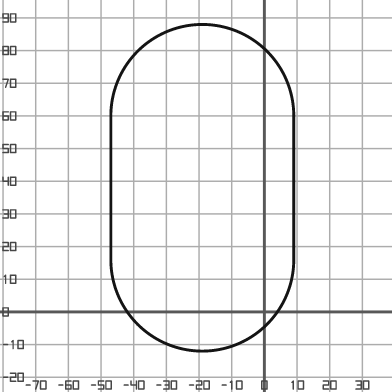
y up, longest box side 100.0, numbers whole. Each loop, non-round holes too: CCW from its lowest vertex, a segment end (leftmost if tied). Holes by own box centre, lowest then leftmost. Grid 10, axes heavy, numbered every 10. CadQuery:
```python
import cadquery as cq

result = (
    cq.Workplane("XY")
    .moveTo(-47.0, 16.0)
    .threePointArc((-19.0, -12.0), (9.0, 16.0))
    .lineTo(9.0, 60.0)
    .threePointArc((-19.0, 88.0), (-47.0, 60.0))
    .close()
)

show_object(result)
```